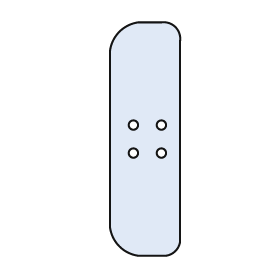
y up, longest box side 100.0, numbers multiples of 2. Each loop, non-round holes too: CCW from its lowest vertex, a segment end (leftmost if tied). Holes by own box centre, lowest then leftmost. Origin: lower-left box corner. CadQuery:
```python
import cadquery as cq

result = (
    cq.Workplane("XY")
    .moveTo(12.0, 0.0)
    .lineTo(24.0, 0.0)
    .threePointArc((28.0, 2.0), (30.0, 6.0))
    .lineTo(30.0, 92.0)
    .threePointArc((28.0, 98.0), (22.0, 100.0))
    .lineTo(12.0, 100.0)
    .threePointArc((4.0, 96.0), (0.0, 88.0))
    .lineTo(0.0, 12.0)
    .threePointArc((4.0, 4.0), (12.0, 0.0))
    .close()
    .moveTo(10.0, 44.0)
    .circle(2.0)
    .moveTo(22.0, 44.0)
    .circle(2.0)
    .moveTo(10.0, 56.0)
    .circle(2.0)
    .moveTo(22.0, 56.0)
    .circle(2.0)
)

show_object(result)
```